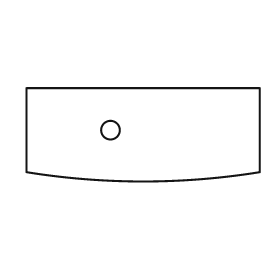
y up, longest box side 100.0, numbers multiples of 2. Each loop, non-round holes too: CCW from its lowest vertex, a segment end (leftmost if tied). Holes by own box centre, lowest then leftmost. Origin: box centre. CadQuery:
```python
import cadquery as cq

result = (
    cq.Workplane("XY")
    .moveTo(-50.0, -16.0)
    .threePointArc((0.0, -20.0), (50.0, -16.0))
    .lineTo(50.0, 20.0)
    .lineTo(-50.0, 20.0)
    .close()
    .moveTo(-14.0, 2.0)
    .circle(4.0)
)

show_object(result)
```